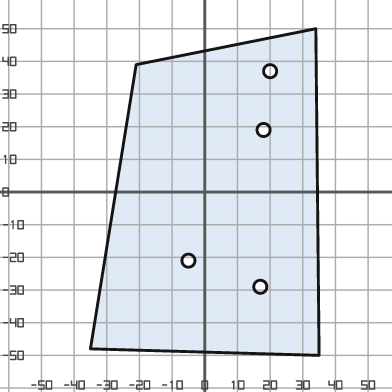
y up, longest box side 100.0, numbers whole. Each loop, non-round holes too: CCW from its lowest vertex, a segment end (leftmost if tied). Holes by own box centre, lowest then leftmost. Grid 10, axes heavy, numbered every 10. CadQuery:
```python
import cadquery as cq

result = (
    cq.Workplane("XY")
    .moveTo(35.0, -50.0)
    .lineTo(34.0, 50.0)
    .lineTo(-21.0, 39.0)
    .lineTo(-35.0, -48.0)
    .close()
    .moveTo(17.0, -29.0)
    .circle(2.0)
    .moveTo(-5.0, -21.0)
    .circle(2.0)
    .moveTo(18.0, 19.0)
    .circle(2.0)
    .moveTo(20.0, 37.0)
    .circle(2.0)
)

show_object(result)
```